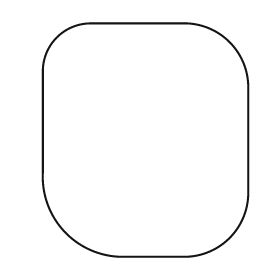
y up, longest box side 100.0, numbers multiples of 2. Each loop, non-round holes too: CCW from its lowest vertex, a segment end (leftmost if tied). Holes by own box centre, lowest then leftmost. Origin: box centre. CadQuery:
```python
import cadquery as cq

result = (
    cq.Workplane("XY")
    .moveTo(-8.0, -50.0)
    .lineTo(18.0, -50.0)
    .threePointArc((36.0, -42.0), (44.0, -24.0))
    .lineTo(44.0, 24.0)
    .threePointArc((36.0, 42.0), (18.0, 50.0))
    .lineTo(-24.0, 50.0)
    .threePointArc((-38.0, 44.0), (-44.0, 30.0))
    .lineTo(-44.0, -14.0)
    .threePointArc((-34.0, -40.0), (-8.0, -50.0))
    .close()
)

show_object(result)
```